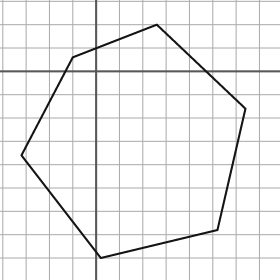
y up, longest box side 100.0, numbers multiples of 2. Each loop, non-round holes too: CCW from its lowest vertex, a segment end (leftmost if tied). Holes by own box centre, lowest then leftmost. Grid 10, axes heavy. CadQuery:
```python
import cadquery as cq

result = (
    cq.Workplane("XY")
    .moveTo(2.0, -80.0)
    .lineTo(52.0, -68.0)
    .lineTo(64.0, -16.0)
    .lineTo(26.0, 20.0)
    .lineTo(-10.0, 6.0)
    .lineTo(-32.0, -36.0)
    .close()
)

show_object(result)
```